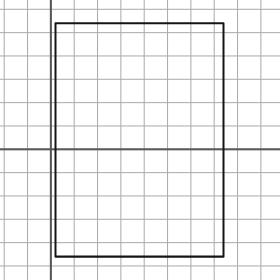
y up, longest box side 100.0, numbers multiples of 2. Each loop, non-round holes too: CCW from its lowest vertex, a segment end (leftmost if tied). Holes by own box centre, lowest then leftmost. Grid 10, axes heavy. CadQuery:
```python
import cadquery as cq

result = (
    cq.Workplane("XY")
    .moveTo(2.0, -46.0)
    .lineTo(74.0, -46.0)
    .lineTo(74.0, 54.0)
    .lineTo(2.0, 54.0)
    .close()
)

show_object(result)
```